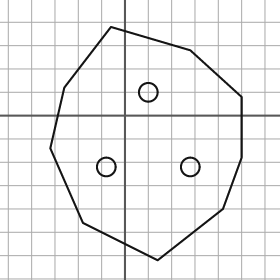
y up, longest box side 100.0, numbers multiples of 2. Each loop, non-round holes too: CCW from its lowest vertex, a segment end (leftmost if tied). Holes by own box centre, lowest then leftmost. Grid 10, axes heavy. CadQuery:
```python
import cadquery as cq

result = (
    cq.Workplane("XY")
    .moveTo(14.0, -62.0)
    .lineTo(42.0, -40.0)
    .lineTo(50.0, -18.0)
    .lineTo(50.0, 8.0)
    .lineTo(28.0, 28.0)
    .lineTo(-6.0, 38.0)
    .lineTo(-26.0, 12.0)
    .lineTo(-32.0, -14.0)
    .lineTo(-18.0, -46.0)
    .close()
    .moveTo(-8.0, -22.0)
    .circle(4.0)
    .moveTo(28.0, -22.0)
    .circle(4.0)
    .moveTo(10.0, 10.0)
    .circle(4.0)
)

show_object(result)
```